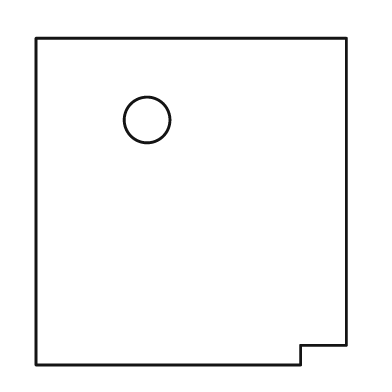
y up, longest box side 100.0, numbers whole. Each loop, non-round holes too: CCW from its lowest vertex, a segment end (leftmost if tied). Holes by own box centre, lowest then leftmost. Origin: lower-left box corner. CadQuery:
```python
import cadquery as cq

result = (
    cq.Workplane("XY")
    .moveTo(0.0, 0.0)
    .lineTo(81.0, 0.0)
    .lineTo(81.0, 6.0)
    .lineTo(95.0, 6.0)
    .lineTo(95.0, 100.0)
    .lineTo(0.0, 100.0)
    .close()
    .moveTo(34.0, 75.0)
    .circle(7.0)
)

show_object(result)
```